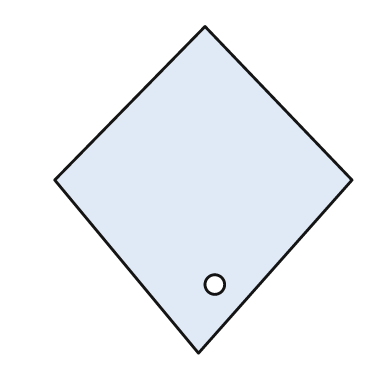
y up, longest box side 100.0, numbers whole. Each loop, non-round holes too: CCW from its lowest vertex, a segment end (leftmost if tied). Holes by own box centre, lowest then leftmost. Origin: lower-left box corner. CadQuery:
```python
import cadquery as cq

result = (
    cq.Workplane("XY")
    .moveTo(44.0, 0.0)
    .lineTo(91.0, 53.0)
    .lineTo(46.0, 100.0)
    .lineTo(0.0, 53.0)
    .close()
    .moveTo(49.0, 21.0)
    .circle(3.0)
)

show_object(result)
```